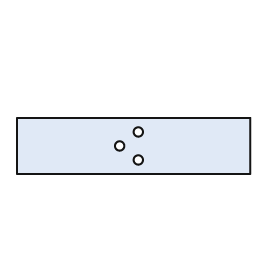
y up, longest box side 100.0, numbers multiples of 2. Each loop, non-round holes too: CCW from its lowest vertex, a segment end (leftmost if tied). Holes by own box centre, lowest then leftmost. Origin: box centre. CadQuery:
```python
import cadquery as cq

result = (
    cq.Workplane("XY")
    .moveTo(-50.0, -12.0)
    .lineTo(50.0, -12.0)
    .lineTo(50.0, 12.0)
    .lineTo(-50.0, 12.0)
    .close()
    .moveTo(2.0, -6.0)
    .circle(2.0)
    .moveTo(-6.0, 0.0)
    .circle(2.0)
    .moveTo(2.0, 6.0)
    .circle(2.0)
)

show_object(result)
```